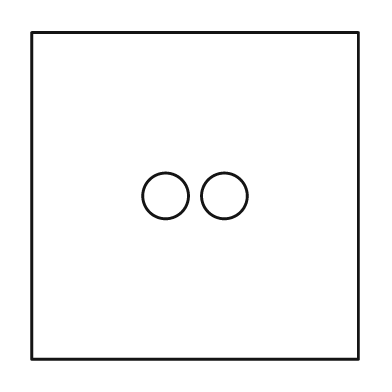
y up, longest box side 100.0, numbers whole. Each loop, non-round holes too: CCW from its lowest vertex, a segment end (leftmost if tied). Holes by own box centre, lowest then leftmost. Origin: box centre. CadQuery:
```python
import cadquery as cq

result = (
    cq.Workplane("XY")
    .moveTo(-50.0, -50.0)
    .lineTo(50.0, -50.0)
    .lineTo(50.0, 50.0)
    .lineTo(-50.0, 50.0)
    .close()
    .moveTo(-9.0, 0.0)
    .circle(7.0)
    .moveTo(9.0, 0.0)
    .circle(7.0)
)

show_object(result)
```